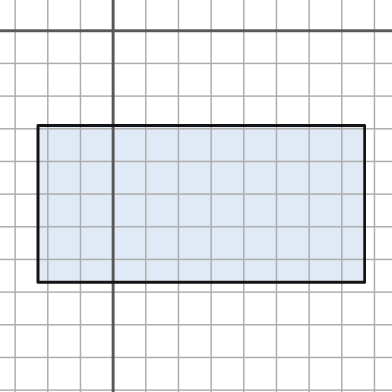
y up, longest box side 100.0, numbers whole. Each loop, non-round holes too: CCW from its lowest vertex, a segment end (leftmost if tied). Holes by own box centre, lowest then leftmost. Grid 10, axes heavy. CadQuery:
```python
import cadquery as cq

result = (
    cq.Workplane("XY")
    .moveTo(-23.0, -77.0)
    .lineTo(77.0, -77.0)
    .lineTo(77.0, -29.0)
    .lineTo(-23.0, -29.0)
    .close()
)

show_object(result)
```